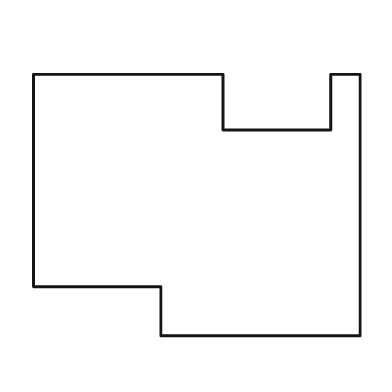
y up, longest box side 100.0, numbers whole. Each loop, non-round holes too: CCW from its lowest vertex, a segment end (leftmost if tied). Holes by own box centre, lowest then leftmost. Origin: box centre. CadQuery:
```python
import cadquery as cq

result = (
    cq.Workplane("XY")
    .moveTo(-11.0, -40.0)
    .lineTo(50.0, -40.0)
    .lineTo(50.0, 40.0)
    .lineTo(41.0, 40.0)
    .lineTo(41.0, 23.0)
    .lineTo(8.0, 23.0)
    .lineTo(8.0, 40.0)
    .lineTo(-50.0, 40.0)
    .lineTo(-50.0, -25.0)
    .lineTo(-11.0, -25.0)
    .close()
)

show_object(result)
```